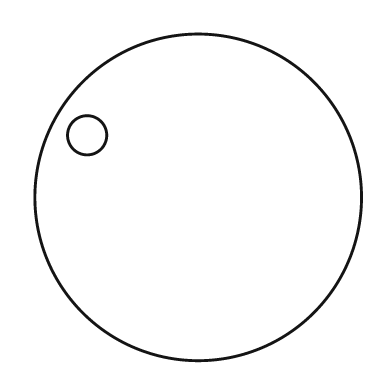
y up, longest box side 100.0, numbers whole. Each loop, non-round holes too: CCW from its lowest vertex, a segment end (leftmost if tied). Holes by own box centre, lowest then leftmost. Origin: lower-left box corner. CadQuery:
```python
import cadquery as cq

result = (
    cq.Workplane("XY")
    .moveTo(50.0, 50.0)
    .circle(50.0)
    .moveTo(16.0, 69.0)
    .circle(6.0)
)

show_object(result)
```